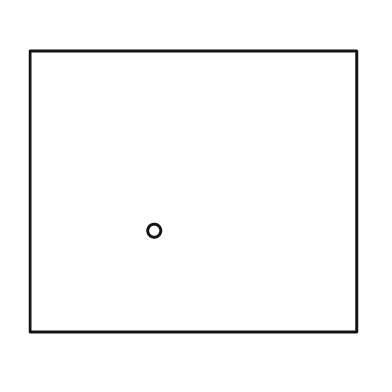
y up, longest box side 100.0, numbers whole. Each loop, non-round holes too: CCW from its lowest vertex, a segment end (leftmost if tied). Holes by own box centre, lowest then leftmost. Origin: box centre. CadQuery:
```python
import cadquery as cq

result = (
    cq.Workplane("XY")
    .moveTo(-50.0, -43.0)
    .lineTo(50.0, -43.0)
    .lineTo(50.0, 43.0)
    .lineTo(-50.0, 43.0)
    .close()
    .moveTo(-12.0, -12.0)
    .circle(2.0)
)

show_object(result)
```